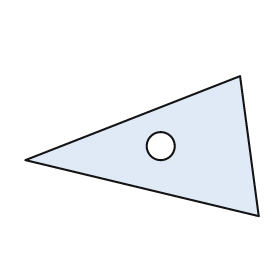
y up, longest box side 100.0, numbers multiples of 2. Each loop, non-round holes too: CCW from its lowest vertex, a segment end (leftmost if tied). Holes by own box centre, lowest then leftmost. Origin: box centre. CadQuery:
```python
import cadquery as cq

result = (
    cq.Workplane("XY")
    .moveTo(50.0, -30.0)
    .lineTo(42.0, 30.0)
    .lineTo(-50.0, -6.0)
    .close()
    .moveTo(8.0, 0.0)
    .circle(6.0)
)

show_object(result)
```